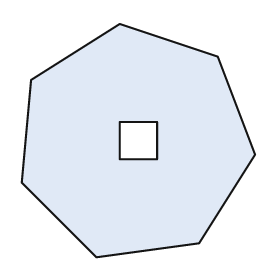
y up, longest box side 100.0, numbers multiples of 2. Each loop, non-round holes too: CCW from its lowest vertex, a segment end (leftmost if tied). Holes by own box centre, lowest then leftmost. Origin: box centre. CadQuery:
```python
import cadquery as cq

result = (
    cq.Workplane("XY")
    .moveTo(-18.0, -50.0)
    .lineTo(26.0, -44.0)
    .lineTo(50.0, -6.0)
    .lineTo(34.0, 36.0)
    .lineTo(-8.0, 50.0)
    .lineTo(-46.0, 26.0)
    .lineTo(-50.0, -18.0)
    .close()
    .moveTo(-8.0, -8.0)
    .lineTo(8.0, -8.0)
    .lineTo(8.0, 8.0)
    .lineTo(-8.0, 8.0)
    .close()
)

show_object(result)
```